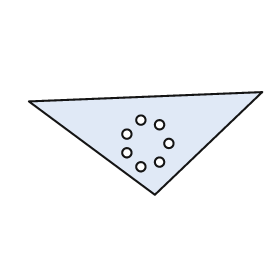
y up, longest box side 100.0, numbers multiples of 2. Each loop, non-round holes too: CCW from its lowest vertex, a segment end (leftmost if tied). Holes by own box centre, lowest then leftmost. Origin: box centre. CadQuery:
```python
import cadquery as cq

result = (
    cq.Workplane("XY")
    .moveTo(4.0, -22.0)
    .lineTo(50.0, 22.0)
    .lineTo(-50.0, 18.0)
    .close()
    .moveTo(-2.0, -10.0)
    .circle(2.0)
    .moveTo(6.0, -8.0)
    .circle(2.0)
    .moveTo(-8.0, -4.0)
    .circle(2.0)
    .moveTo(10.0, 0.0)
    .circle(2.0)
    .moveTo(-8.0, 4.0)
    .circle(2.0)
    .moveTo(6.0, 8.0)
    .circle(2.0)
    .moveTo(-2.0, 10.0)
    .circle(2.0)
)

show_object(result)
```